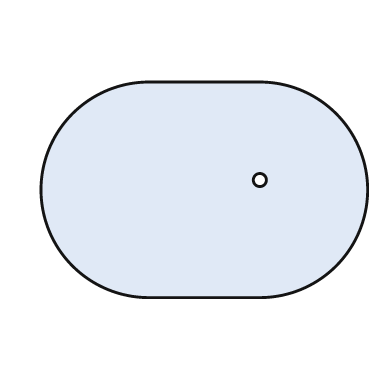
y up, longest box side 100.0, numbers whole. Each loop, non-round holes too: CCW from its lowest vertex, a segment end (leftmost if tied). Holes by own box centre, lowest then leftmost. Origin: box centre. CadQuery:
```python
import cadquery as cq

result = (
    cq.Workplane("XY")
    .moveTo(-17.0, -33.0)
    .lineTo(17.0, -33.0)
    .threePointArc((50.0, 0.0), (17.0, 33.0))
    .lineTo(-17.0, 33.0)
    .threePointArc((-50.0, 0.0), (-17.0, -33.0))
    .close()
    .moveTo(17.0, 3.0)
    .circle(2.0)
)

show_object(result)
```